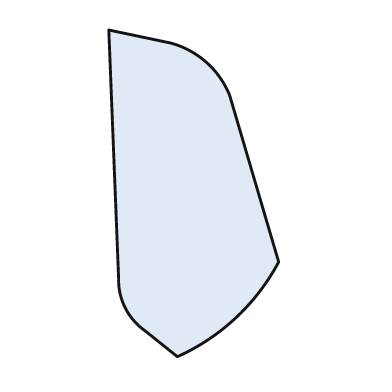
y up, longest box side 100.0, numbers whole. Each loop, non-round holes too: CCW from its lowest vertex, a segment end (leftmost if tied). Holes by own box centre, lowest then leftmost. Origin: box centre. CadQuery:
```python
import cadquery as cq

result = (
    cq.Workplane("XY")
    .moveTo(-5.0, -50.0)
    .threePointArc((13.0, -38.0), (26.0, -21.0))
    .lineTo(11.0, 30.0)
    .threePointArc((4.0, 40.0), (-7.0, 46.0))
    .lineTo(-26.0, 50.0)
    .lineTo(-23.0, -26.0)
    .threePointArc((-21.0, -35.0), (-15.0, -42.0))
    .close()
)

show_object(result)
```